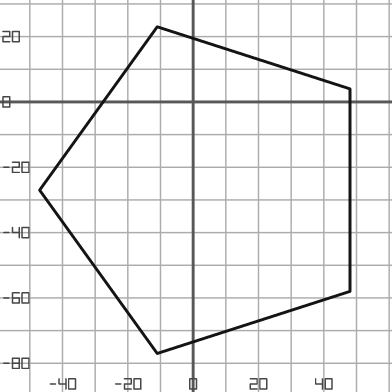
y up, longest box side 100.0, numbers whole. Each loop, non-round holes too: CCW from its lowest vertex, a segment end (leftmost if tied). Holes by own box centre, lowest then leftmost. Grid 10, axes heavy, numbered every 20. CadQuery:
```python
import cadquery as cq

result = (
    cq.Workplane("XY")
    .moveTo(-11.0, -77.0)
    .lineTo(48.0, -58.0)
    .lineTo(48.0, 4.0)
    .lineTo(-11.0, 23.0)
    .lineTo(-47.0, -27.0)
    .close()
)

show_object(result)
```